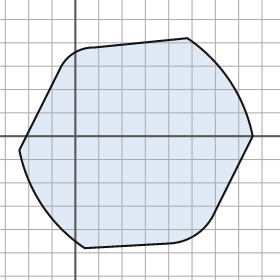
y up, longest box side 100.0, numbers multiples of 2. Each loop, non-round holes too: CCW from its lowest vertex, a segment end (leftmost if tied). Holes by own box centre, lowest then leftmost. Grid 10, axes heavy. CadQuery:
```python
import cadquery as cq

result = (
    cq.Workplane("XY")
    .moveTo(4.0, -48.0)
    .lineTo(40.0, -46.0)
    .threePointArc((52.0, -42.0), (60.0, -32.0))
    .lineTo(76.0, 0.0)
    .threePointArc((66.0, 24.0), (48.0, 42.0))
    .lineTo(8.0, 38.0)
    .threePointArc((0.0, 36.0), (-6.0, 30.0))
    .lineTo(-24.0, -6.0)
    .threePointArc((-14.0, -30.0), (4.0, -48.0))
    .close()
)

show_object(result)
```